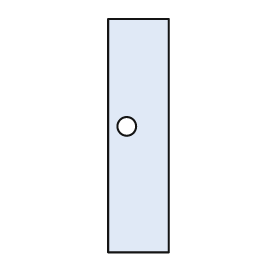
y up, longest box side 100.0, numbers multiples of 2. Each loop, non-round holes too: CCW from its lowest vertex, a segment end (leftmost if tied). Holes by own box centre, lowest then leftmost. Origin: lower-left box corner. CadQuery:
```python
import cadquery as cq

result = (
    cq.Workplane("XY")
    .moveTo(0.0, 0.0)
    .lineTo(26.0, 0.0)
    .lineTo(26.0, 100.0)
    .lineTo(0.0, 100.0)
    .close()
    .moveTo(8.0, 54.0)
    .circle(4.0)
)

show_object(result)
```